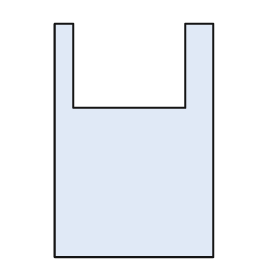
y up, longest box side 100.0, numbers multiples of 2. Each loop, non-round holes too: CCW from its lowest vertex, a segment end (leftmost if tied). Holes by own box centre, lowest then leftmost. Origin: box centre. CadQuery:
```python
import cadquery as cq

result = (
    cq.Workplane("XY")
    .moveTo(-34.0, -50.0)
    .lineTo(34.0, -50.0)
    .lineTo(34.0, 50.0)
    .lineTo(22.0, 50.0)
    .lineTo(22.0, 14.0)
    .lineTo(-26.0, 14.0)
    .lineTo(-26.0, 50.0)
    .lineTo(-34.0, 50.0)
    .close()
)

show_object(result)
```